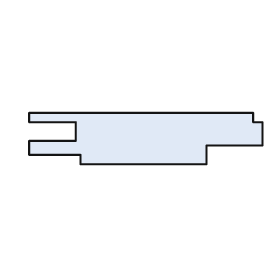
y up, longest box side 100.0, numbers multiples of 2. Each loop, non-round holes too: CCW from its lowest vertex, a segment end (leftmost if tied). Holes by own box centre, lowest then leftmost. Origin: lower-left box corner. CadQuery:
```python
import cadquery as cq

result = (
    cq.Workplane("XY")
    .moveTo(22.0, 0.0)
    .lineTo(76.0, 0.0)
    .lineTo(76.0, 8.0)
    .lineTo(100.0, 8.0)
    .lineTo(100.0, 18.0)
    .lineTo(96.0, 18.0)
    .lineTo(96.0, 22.0)
    .lineTo(0.0, 22.0)
    .lineTo(0.0, 18.0)
    .lineTo(20.0, 18.0)
    .lineTo(20.0, 10.0)
    .lineTo(0.0, 10.0)
    .lineTo(0.0, 4.0)
    .lineTo(22.0, 4.0)
    .close()
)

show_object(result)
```